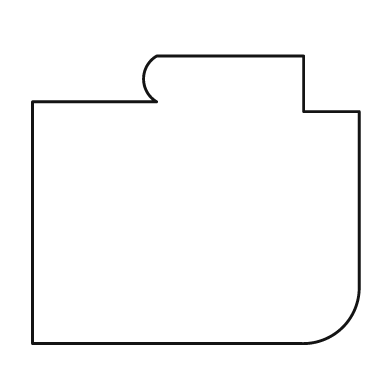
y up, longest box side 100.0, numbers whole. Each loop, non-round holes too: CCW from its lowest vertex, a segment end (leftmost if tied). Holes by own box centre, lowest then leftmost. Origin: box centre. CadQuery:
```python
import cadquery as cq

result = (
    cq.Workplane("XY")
    .moveTo(-50.0, -44.0)
    .lineTo(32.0, -44.0)
    .threePointArc((45.0, -39.0), (50.0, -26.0))
    .lineTo(50.0, 27.0)
    .lineTo(33.0, 27.0)
    .lineTo(33.0, 44.0)
    .lineTo(-12.0, 44.0)
    .threePointArc((-16.0, 37.0), (-12.0, 30.0))
    .lineTo(-50.0, 30.0)
    .close()
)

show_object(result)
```